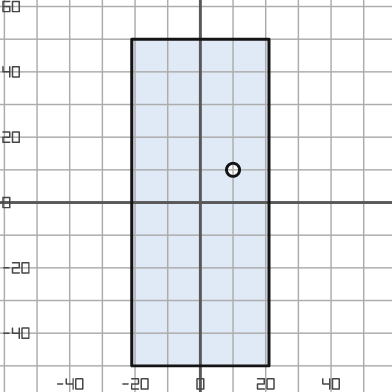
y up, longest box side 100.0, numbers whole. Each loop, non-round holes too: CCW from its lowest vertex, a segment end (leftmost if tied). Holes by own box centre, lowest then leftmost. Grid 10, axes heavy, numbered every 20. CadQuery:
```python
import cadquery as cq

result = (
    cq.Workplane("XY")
    .moveTo(-21.0, -50.0)
    .lineTo(21.0, -50.0)
    .lineTo(21.0, 50.0)
    .lineTo(-21.0, 50.0)
    .close()
    .moveTo(10.0, 10.0)
    .circle(2.0)
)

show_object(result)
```